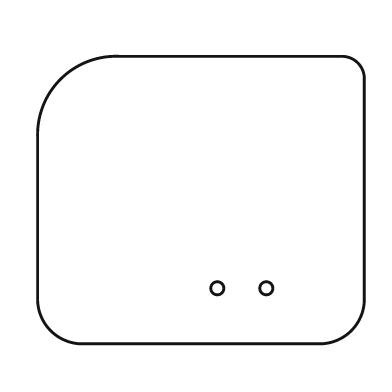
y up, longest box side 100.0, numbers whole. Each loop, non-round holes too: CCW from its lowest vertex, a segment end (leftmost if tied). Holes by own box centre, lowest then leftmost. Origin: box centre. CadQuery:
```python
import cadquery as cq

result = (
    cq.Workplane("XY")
    .moveTo(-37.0, -44.0)
    .lineTo(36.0, -44.0)
    .threePointArc((46.0, -40.0), (50.0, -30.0))
    .lineTo(50.0, 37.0)
    .threePointArc((48.0, 42.0), (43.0, 44.0))
    .lineTo(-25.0, 44.0)
    .threePointArc((-43.0, 37.0), (-50.0, 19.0))
    .lineTo(-50.0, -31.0)
    .threePointArc((-46.0, -40.0), (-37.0, -44.0))
    .close()
    .moveTo(5.0, -27.0)
    .circle(2.0)
    .moveTo(20.0, -27.0)
    .circle(2.0)
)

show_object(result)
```